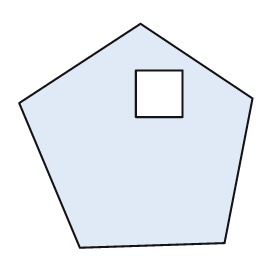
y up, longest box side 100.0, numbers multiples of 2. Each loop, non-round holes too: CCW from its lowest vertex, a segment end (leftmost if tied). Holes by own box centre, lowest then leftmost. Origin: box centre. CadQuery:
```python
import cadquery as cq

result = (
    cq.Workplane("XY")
    .moveTo(-24.0, -48.0)
    .lineTo(38.0, -46.0)
    .lineTo(50.0, 16.0)
    .lineTo(2.0, 48.0)
    .lineTo(-50.0, 14.0)
    .close()
    .moveTo(0.0, 8.0)
    .lineTo(20.0, 8.0)
    .lineTo(20.0, 28.0)
    .lineTo(0.0, 28.0)
    .close()
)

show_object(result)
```